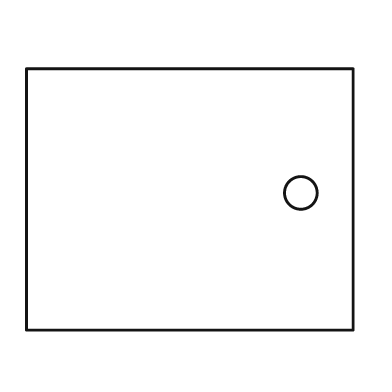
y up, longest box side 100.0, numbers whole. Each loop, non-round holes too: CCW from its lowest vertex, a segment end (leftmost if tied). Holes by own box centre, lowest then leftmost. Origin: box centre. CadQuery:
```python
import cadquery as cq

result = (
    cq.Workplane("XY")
    .moveTo(-50.0, -40.0)
    .lineTo(50.0, -40.0)
    .lineTo(50.0, 40.0)
    .lineTo(-50.0, 40.0)
    .close()
    .moveTo(34.0, 2.0)
    .circle(5.0)
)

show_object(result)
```